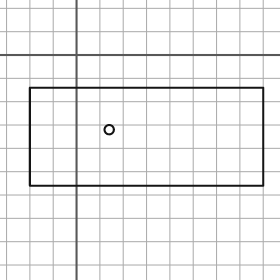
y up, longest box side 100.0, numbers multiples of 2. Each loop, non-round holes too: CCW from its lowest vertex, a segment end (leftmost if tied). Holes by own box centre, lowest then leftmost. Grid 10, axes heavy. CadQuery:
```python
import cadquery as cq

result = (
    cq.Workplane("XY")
    .moveTo(-20.0, -56.0)
    .lineTo(80.0, -56.0)
    .lineTo(80.0, -14.0)
    .lineTo(-20.0, -14.0)
    .close()
    .moveTo(14.0, -32.0)
    .circle(2.0)
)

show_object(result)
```